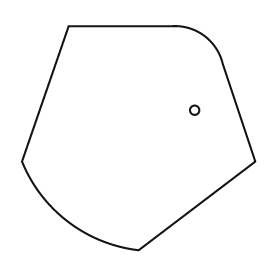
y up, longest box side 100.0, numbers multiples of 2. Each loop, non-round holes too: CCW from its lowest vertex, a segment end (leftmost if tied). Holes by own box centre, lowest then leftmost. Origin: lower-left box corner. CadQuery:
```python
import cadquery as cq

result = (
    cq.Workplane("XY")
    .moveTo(50.0, 0.0)
    .lineTo(100.0, 38.0)
    .lineTo(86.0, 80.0)
    .threePointArc((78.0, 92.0), (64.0, 96.0))
    .lineTo(20.0, 96.0)
    .lineTo(0.0, 38.0)
    .threePointArc((20.0, 12.0), (50.0, 0.0))
    .close()
    .moveTo(74.0, 60.0)
    .circle(2.0)
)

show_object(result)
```